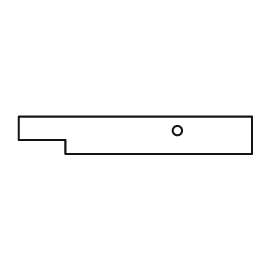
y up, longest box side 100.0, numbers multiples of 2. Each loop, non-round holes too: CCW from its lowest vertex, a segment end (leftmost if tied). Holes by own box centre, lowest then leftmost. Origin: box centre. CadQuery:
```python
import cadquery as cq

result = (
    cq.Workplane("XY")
    .moveTo(-30.0, -8.0)
    .lineTo(50.0, -8.0)
    .lineTo(50.0, 8.0)
    .lineTo(-50.0, 8.0)
    .lineTo(-50.0, -2.0)
    .lineTo(-30.0, -2.0)
    .close()
    .moveTo(18.0, 2.0)
    .circle(2.0)
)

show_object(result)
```